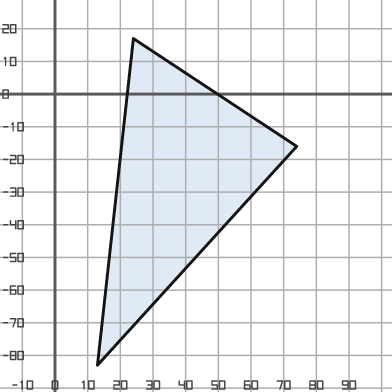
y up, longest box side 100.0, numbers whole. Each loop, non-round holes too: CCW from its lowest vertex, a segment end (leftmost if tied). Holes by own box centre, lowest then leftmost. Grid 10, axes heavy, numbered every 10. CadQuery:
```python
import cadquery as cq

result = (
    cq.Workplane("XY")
    .moveTo(13.0, -83.0)
    .lineTo(74.0, -16.0)
    .lineTo(24.0, 17.0)
    .close()
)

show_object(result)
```